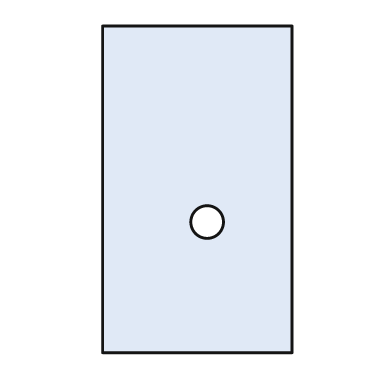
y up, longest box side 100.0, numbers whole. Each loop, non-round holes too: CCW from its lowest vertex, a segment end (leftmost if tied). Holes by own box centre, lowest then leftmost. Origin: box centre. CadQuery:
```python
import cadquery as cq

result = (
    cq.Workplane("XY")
    .moveTo(-29.0, -50.0)
    .lineTo(29.0, -50.0)
    .lineTo(29.0, 50.0)
    .lineTo(-29.0, 50.0)
    .close()
    .moveTo(3.0, -10.0)
    .circle(5.0)
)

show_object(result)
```